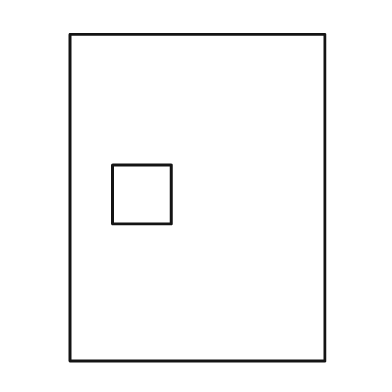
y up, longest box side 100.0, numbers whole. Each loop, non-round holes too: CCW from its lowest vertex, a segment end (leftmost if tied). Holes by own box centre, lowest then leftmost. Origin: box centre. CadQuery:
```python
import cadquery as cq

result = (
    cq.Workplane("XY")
    .moveTo(-39.0, -50.0)
    .lineTo(39.0, -50.0)
    .lineTo(39.0, 50.0)
    .lineTo(-39.0, 50.0)
    .close()
    .moveTo(-26.0, -8.0)
    .lineTo(-8.0, -8.0)
    .lineTo(-8.0, 10.0)
    .lineTo(-26.0, 10.0)
    .close()
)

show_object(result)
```